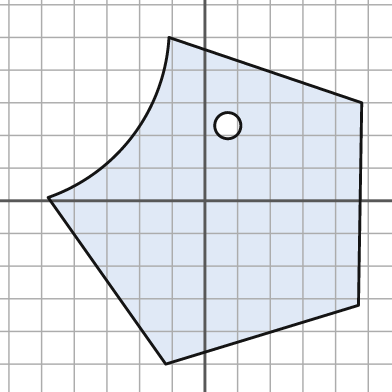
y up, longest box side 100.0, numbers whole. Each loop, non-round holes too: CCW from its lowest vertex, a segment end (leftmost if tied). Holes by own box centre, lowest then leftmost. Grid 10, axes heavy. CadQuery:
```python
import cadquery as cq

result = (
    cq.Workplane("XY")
    .moveTo(-12.0, -50.0)
    .lineTo(47.0, -32.0)
    .lineTo(48.0, 30.0)
    .lineTo(-11.0, 50.0)
    .threePointArc((-22.0, 20.0), (-48.0, 1.0))
    .close()
    .moveTo(7.0, 23.0)
    .circle(4.0)
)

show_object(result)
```